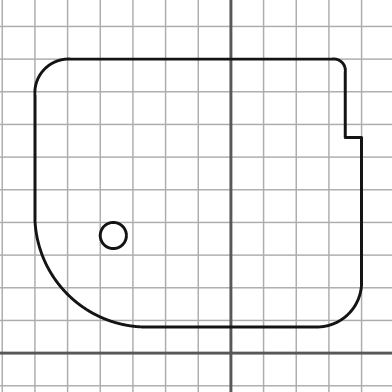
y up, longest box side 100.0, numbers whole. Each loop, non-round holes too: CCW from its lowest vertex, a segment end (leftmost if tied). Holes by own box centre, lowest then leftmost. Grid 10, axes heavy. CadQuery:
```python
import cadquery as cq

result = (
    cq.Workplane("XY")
    .moveTo(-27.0, 8.0)
    .lineTo(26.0, 8.0)
    .threePointArc((36.0, 12.0), (40.0, 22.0))
    .lineTo(40.0, 66.0)
    .lineTo(35.0, 66.0)
    .lineTo(35.0, 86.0)
    .threePointArc((34.0, 89.0), (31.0, 90.0))
    .lineTo(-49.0, 90.0)
    .threePointArc((-57.0, 87.0), (-60.0, 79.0))
    .lineTo(-60.0, 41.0)
    .threePointArc((-50.0, 18.0), (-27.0, 8.0))
    .close()
    .moveTo(-36.0, 36.0)
    .circle(4.0)
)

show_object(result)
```